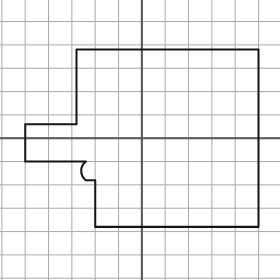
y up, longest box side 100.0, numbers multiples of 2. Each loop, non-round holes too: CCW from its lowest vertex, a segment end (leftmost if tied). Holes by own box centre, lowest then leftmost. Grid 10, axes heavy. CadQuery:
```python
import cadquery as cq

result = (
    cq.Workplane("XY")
    .moveTo(-20.0, -38.0)
    .lineTo(50.0, -38.0)
    .lineTo(50.0, 38.0)
    .lineTo(-28.0, 38.0)
    .lineTo(-28.0, 6.0)
    .lineTo(-50.0, 6.0)
    .lineTo(-50.0, -10.0)
    .lineTo(-24.0, -10.0)
    .threePointArc((-26.0, -14.0), (-24.0, -18.0))
    .lineTo(-20.0, -18.0)
    .close()
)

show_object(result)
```